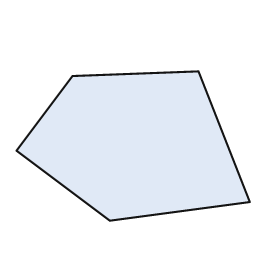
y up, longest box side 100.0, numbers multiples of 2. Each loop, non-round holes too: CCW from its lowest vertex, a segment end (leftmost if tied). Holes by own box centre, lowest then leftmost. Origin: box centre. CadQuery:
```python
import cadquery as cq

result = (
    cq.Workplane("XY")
    .moveTo(-10.0, -32.0)
    .lineTo(50.0, -24.0)
    .lineTo(28.0, 32.0)
    .lineTo(-26.0, 30.0)
    .lineTo(-50.0, -2.0)
    .close()
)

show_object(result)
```